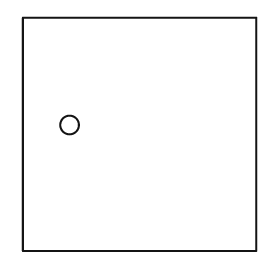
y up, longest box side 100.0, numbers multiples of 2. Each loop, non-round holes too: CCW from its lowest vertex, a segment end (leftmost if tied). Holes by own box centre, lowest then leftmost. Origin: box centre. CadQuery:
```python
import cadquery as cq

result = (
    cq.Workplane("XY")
    .moveTo(-50.0, -50.0)
    .lineTo(50.0, -50.0)
    .lineTo(50.0, 50.0)
    .lineTo(-50.0, 50.0)
    .close()
    .moveTo(-30.0, 4.0)
    .circle(4.0)
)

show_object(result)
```